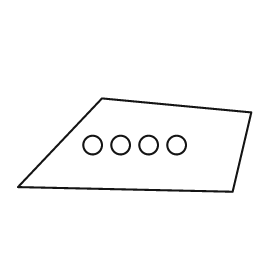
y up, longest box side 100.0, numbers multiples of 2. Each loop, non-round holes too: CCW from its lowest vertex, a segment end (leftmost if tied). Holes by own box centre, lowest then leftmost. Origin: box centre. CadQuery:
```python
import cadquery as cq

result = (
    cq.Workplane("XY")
    .moveTo(42.0, -20.0)
    .lineTo(50.0, 14.0)
    .lineTo(-14.0, 20.0)
    .lineTo(-50.0, -18.0)
    .close()
    .moveTo(-18.0, 0.0)
    .circle(4.0)
    .moveTo(-6.0, 0.0)
    .circle(4.0)
    .moveTo(6.0, 0.0)
    .circle(4.0)
    .moveTo(18.0, 0.0)
    .circle(4.0)
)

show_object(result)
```